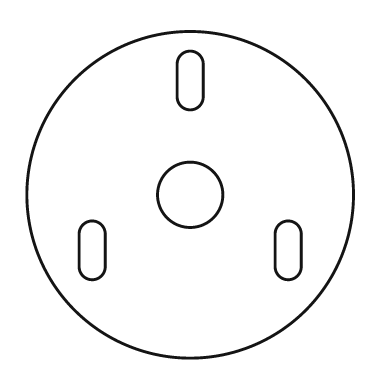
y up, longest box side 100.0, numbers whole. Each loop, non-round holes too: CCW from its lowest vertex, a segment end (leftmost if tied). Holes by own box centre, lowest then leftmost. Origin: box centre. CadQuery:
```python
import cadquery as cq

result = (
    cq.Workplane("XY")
    .moveTo(0.0, 0.0)
    .circle(50.0)
    .moveTo(-34.0, -22.0)
    .threePointArc((-30.0, -26.0), (-26.0, -22.0))
    .lineTo(-26.0, -12.0)
    .threePointArc((-30.0, -8.0), (-34.0, -12.0))
    .close()
    .moveTo(26.0, -22.0)
    .threePointArc((30.0, -26.0), (34.0, -22.0))
    .lineTo(34.0, -12.0)
    .threePointArc((30.0, -8.0), (26.0, -12.0))
    .close()
    .moveTo(0.0, 0.0)
    .circle(10.0)
    .moveTo(-4.0, 30.0)
    .threePointArc((0.0, 26.0), (4.0, 30.0))
    .lineTo(4.0, 40.0)
    .threePointArc((0.0, 44.0), (-4.0, 40.0))
    .close()
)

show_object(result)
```